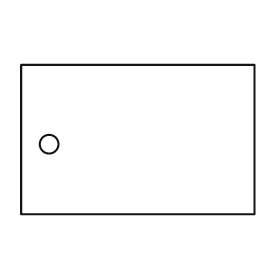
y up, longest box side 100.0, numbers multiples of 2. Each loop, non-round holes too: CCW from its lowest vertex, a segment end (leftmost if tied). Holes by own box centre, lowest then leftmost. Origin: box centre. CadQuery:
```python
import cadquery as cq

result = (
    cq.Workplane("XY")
    .moveTo(-50.0, -32.0)
    .lineTo(50.0, -32.0)
    .lineTo(50.0, 32.0)
    .lineTo(-50.0, 32.0)
    .close()
    .moveTo(-38.0, -2.0)
    .circle(4.0)
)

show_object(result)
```